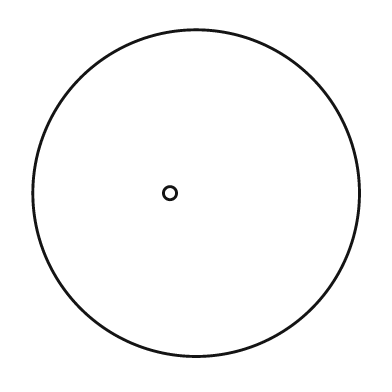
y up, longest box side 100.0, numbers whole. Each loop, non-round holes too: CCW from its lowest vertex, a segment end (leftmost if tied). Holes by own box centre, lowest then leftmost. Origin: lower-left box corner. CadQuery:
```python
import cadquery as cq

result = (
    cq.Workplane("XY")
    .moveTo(50.0, 50.0)
    .circle(50.0)
    .moveTo(42.0, 50.0)
    .circle(2.0)
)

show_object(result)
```